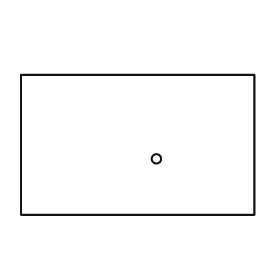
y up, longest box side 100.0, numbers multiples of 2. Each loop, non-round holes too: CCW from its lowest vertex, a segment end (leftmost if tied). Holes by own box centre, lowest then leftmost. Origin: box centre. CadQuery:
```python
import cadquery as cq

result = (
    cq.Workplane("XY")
    .moveTo(-50.0, -30.0)
    .lineTo(50.0, -30.0)
    .lineTo(50.0, 30.0)
    .lineTo(-50.0, 30.0)
    .close()
    .moveTo(8.0, -6.0)
    .circle(2.0)
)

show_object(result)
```